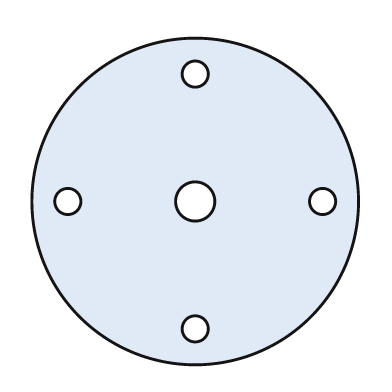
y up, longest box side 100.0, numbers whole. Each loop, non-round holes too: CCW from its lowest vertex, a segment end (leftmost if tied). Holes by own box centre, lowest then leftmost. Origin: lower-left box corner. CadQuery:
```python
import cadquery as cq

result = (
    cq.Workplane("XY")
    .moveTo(50.0, 50.0)
    .circle(50.0)
    .moveTo(50.0, 11.0)
    .circle(4.0)
    .moveTo(11.0, 50.0)
    .circle(4.0)
    .moveTo(50.0, 50.0)
    .circle(6.0)
    .moveTo(89.0, 50.0)
    .circle(4.0)
    .moveTo(50.0, 89.0)
    .circle(4.0)
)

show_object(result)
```